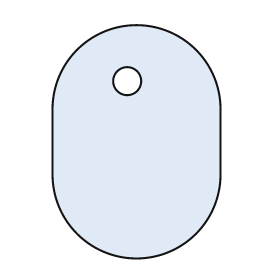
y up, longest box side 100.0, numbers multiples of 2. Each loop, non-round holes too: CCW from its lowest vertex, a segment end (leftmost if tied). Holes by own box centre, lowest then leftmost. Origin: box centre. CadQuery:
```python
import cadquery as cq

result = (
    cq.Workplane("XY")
    .moveTo(-36.0, -14.0)
    .threePointArc((0.0, -50.0), (36.0, -14.0))
    .lineTo(36.0, 14.0)
    .threePointArc((0.0, 50.0), (-36.0, 14.0))
    .close()
    .moveTo(-4.0, 26.0)
    .circle(6.0)
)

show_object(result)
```